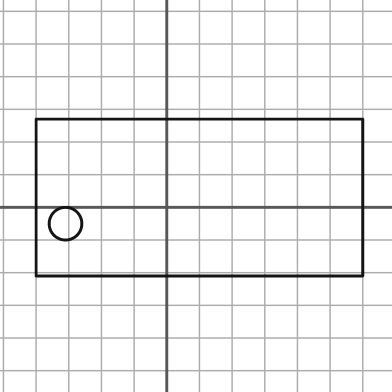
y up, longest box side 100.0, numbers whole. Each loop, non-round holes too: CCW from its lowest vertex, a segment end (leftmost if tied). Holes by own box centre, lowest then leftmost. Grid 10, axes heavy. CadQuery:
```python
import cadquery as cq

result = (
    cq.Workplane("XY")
    .moveTo(-40.0, -21.0)
    .lineTo(60.0, -21.0)
    .lineTo(60.0, 27.0)
    .lineTo(-40.0, 27.0)
    .close()
    .moveTo(-31.0, -5.0)
    .circle(5.0)
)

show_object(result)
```